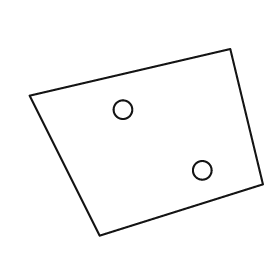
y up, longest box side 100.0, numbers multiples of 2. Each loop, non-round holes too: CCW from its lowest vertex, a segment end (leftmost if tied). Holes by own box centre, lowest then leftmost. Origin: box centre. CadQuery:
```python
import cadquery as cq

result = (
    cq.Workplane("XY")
    .moveTo(-20.0, -40.0)
    .lineTo(50.0, -18.0)
    .lineTo(36.0, 40.0)
    .lineTo(-50.0, 20.0)
    .close()
    .moveTo(24.0, -12.0)
    .circle(4.0)
    .moveTo(-10.0, 14.0)
    .circle(4.0)
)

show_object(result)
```